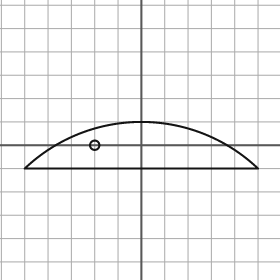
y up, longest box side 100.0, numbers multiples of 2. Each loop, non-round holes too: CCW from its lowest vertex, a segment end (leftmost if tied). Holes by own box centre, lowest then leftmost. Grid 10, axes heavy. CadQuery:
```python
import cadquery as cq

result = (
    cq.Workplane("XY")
    .moveTo(-50.0, -10.0)
    .lineTo(50.0, -10.0)
    .threePointArc((0.0, 10.0), (-50.0, -10.0))
    .close()
    .moveTo(-20.0, 0.0)
    .circle(2.0)
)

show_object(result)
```